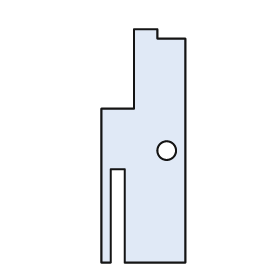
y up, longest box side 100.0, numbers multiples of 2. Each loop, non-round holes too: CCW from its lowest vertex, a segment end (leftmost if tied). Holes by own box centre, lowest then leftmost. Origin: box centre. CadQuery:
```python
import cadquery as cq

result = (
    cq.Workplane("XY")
    .moveTo(-18.0, -50.0)
    .lineTo(-14.0, -50.0)
    .lineTo(-14.0, -10.0)
    .lineTo(-8.0, -10.0)
    .lineTo(-8.0, -50.0)
    .lineTo(18.0, -50.0)
    .lineTo(18.0, 46.0)
    .lineTo(6.0, 46.0)
    .lineTo(6.0, 50.0)
    .lineTo(-4.0, 50.0)
    .lineTo(-4.0, 16.0)
    .lineTo(-18.0, 16.0)
    .close()
    .moveTo(10.0, -2.0)
    .circle(4.0)
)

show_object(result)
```